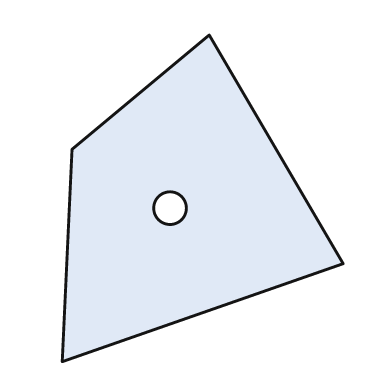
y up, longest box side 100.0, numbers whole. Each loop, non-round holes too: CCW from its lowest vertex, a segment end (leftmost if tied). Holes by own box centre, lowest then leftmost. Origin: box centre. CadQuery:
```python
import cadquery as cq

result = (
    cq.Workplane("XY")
    .moveTo(-43.0, -50.0)
    .lineTo(43.0, -20.0)
    .lineTo(2.0, 50.0)
    .lineTo(-40.0, 15.0)
    .close()
    .moveTo(-10.0, -3.0)
    .circle(5.0)
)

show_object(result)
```